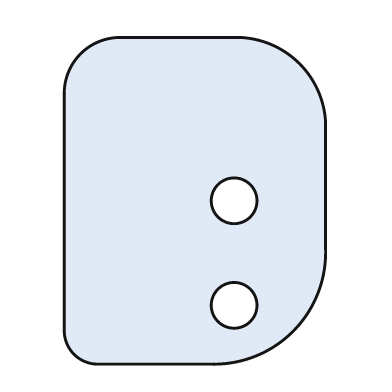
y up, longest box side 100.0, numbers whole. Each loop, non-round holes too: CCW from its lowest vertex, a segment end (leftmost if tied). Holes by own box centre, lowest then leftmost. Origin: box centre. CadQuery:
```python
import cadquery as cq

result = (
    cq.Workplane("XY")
    .moveTo(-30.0, -50.0)
    .lineTo(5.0, -50.0)
    .threePointArc((30.0, -40.0), (40.0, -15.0))
    .lineTo(40.0, 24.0)
    .threePointArc((32.0, 42.0), (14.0, 50.0))
    .lineTo(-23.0, 50.0)
    .threePointArc((-35.0, 45.0), (-40.0, 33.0))
    .lineTo(-40.0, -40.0)
    .threePointArc((-37.0, -47.0), (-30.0, -50.0))
    .close()
    .moveTo(12.0, -32.0)
    .circle(7.0)
    .moveTo(12.0, 0.0)
    .circle(7.0)
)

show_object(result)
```